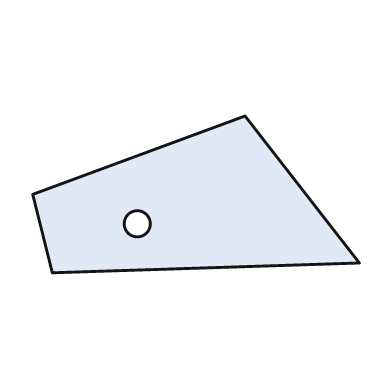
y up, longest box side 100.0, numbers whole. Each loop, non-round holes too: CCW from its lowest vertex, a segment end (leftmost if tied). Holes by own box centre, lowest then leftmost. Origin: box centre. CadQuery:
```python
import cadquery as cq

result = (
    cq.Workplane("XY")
    .moveTo(-44.0, -24.0)
    .lineTo(50.0, -21.0)
    .lineTo(15.0, 24.0)
    .lineTo(-50.0, 0.0)
    .close()
    .moveTo(-18.0, -9.0)
    .circle(4.0)
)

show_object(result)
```